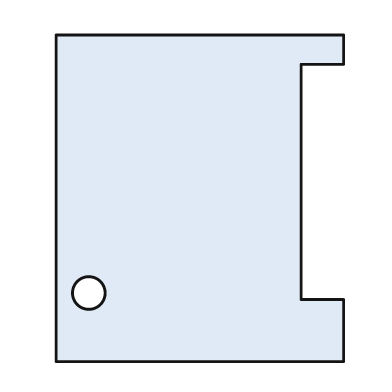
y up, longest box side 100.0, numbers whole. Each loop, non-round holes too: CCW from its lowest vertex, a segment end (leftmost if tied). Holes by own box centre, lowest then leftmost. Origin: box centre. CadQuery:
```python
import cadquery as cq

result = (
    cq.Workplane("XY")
    .moveTo(-44.0, -50.0)
    .lineTo(44.0, -50.0)
    .lineTo(44.0, -31.0)
    .lineTo(31.0, -31.0)
    .lineTo(31.0, 41.0)
    .lineTo(44.0, 41.0)
    .lineTo(44.0, 50.0)
    .lineTo(-44.0, 50.0)
    .close()
    .moveTo(-34.0, -29.0)
    .circle(5.0)
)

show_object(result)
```